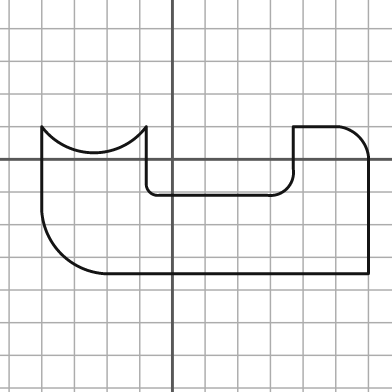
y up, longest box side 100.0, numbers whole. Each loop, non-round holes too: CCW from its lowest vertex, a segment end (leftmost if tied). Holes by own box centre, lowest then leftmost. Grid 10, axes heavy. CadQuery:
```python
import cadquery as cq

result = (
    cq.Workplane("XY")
    .moveTo(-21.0, -35.0)
    .lineTo(60.0, -35.0)
    .lineTo(60.0, 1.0)
    .threePointArc((57.0, 7.0), (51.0, 10.0))
    .lineTo(37.0, 10.0)
    .lineTo(37.0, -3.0)
    .threePointArc((35.0, -9.0), (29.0, -11.0))
    .lineTo(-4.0, -11.0)
    .threePointArc((-7.0, -10.0), (-8.0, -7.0))
    .lineTo(-8.0, 10.0)
    .threePointArc((-24.0, 2.0), (-40.0, 10.0))
    .lineTo(-40.0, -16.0)
    .threePointArc((-34.0, -29.0), (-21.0, -35.0))
    .close()
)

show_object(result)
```